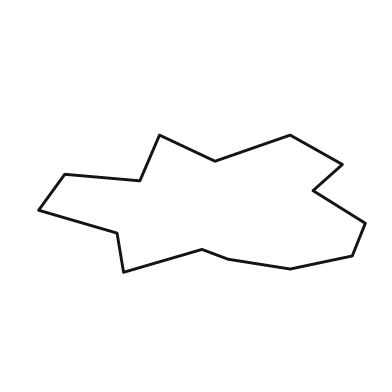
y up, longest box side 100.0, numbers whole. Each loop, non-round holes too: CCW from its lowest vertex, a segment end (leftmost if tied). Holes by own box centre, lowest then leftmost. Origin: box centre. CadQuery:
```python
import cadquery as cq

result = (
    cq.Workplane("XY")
    .moveTo(-24.0, -21.0)
    .lineTo(0.0, -14.0)
    .lineTo(8.0, -17.0)
    .lineTo(27.0, -20.0)
    .lineTo(46.0, -16.0)
    .lineTo(50.0, -6.0)
    .lineTo(34.0, 4.0)
    .lineTo(43.0, 12.0)
    .lineTo(27.0, 21.0)
    .lineTo(4.0, 13.0)
    .lineTo(-13.0, 21.0)
    .lineTo(-19.0, 7.0)
    .lineTo(-42.0, 9.0)
    .lineTo(-50.0, -2.0)
    .lineTo(-26.0, -9.0)
    .close()
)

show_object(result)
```